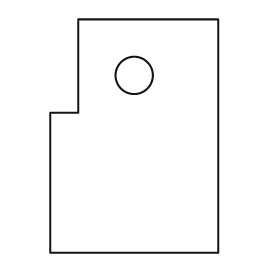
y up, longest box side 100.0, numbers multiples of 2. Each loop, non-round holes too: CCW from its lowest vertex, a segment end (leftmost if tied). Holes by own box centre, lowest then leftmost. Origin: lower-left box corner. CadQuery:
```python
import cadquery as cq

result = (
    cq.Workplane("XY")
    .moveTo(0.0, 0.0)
    .lineTo(72.0, 0.0)
    .lineTo(72.0, 100.0)
    .lineTo(12.0, 100.0)
    .lineTo(12.0, 60.0)
    .lineTo(0.0, 60.0)
    .close()
    .moveTo(36.0, 76.0)
    .circle(8.0)
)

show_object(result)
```